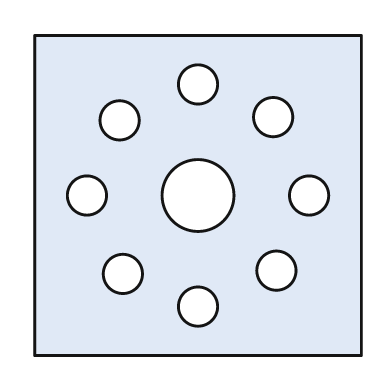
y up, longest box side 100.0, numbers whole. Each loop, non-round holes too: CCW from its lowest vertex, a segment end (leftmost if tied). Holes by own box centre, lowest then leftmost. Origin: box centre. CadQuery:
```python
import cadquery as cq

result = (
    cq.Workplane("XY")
    .moveTo(-50.0, -49.0)
    .lineTo(50.0, -49.0)
    .lineTo(50.0, 49.0)
    .lineTo(-50.0, 49.0)
    .close()
    .moveTo(0.0, -34.0)
    .circle(6.0)
    .moveTo(-23.0, -24.0)
    .circle(6.0)
    .moveTo(24.0, -23.0)
    .circle(6.0)
    .moveTo(-34.0, 0.0)
    .circle(6.0)
    .moveTo(0.0, 0.0)
    .circle(11.0)
    .moveTo(34.0, 0.0)
    .circle(6.0)
    .moveTo(-24.0, 23.0)
    .circle(6.0)
    .moveTo(23.0, 24.0)
    .circle(6.0)
    .moveTo(0.0, 34.0)
    .circle(6.0)
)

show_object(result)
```